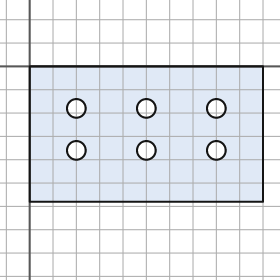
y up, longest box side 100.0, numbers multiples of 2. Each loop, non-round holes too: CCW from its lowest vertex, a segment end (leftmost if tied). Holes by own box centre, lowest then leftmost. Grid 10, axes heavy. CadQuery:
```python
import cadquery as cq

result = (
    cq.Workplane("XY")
    .moveTo(0.0, -58.0)
    .lineTo(100.0, -58.0)
    .lineTo(100.0, 0.0)
    .lineTo(0.0, 0.0)
    .close()
    .moveTo(20.0, -36.0)
    .circle(4.0)
    .moveTo(50.0, -36.0)
    .circle(4.0)
    .moveTo(80.0, -36.0)
    .circle(4.0)
    .moveTo(20.0, -18.0)
    .circle(4.0)
    .moveTo(50.0, -18.0)
    .circle(4.0)
    .moveTo(80.0, -18.0)
    .circle(4.0)
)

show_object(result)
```